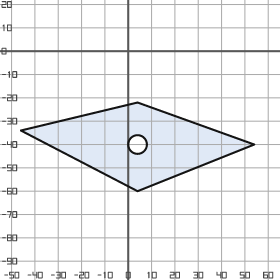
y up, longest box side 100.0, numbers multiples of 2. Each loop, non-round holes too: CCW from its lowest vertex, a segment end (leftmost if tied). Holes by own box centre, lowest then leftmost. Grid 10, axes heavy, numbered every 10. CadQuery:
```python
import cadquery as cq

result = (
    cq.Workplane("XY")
    .moveTo(4.0, -60.0)
    .lineTo(54.0, -40.0)
    .lineTo(4.0, -22.0)
    .lineTo(-46.0, -34.0)
    .close()
    .moveTo(4.0, -40.0)
    .circle(4.0)
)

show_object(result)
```